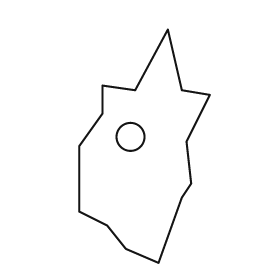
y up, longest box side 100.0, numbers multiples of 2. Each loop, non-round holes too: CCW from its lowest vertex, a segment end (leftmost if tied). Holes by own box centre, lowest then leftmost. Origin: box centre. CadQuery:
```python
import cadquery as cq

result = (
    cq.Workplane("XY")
    .moveTo(6.0, -50.0)
    .lineTo(16.0, -22.0)
    .lineTo(20.0, -16.0)
    .lineTo(18.0, 2.0)
    .lineTo(28.0, 22.0)
    .lineTo(16.0, 24.0)
    .lineTo(10.0, 50.0)
    .lineTo(-4.0, 24.0)
    .lineTo(-18.0, 26.0)
    .lineTo(-18.0, 14.0)
    .lineTo(-28.0, 0.0)
    .lineTo(-28.0, -28.0)
    .lineTo(-16.0, -34.0)
    .lineTo(-8.0, -44.0)
    .close()
    .moveTo(-6.0, 4.0)
    .circle(6.0)
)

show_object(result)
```